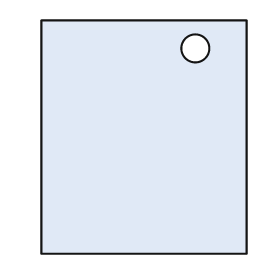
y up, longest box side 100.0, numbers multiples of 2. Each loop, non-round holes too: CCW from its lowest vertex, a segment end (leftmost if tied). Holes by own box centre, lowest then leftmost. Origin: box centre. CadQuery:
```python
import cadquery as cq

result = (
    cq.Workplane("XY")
    .moveTo(-44.0, -50.0)
    .lineTo(44.0, -50.0)
    .lineTo(44.0, 50.0)
    .lineTo(-44.0, 50.0)
    .close()
    .moveTo(22.0, 38.0)
    .circle(6.0)
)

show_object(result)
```